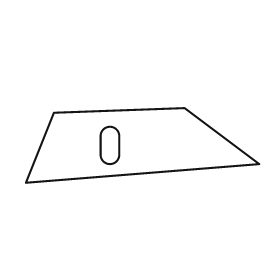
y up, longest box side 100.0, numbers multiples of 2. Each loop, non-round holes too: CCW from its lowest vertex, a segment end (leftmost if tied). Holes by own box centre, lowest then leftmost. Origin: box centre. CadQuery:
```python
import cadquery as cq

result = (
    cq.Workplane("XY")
    .moveTo(-50.0, -16.0)
    .lineTo(50.0, -8.0)
    .lineTo(18.0, 16.0)
    .lineTo(-38.0, 14.0)
    .close()
    .moveTo(-18.0, -4.0)
    .threePointArc((-14.0, -8.0), (-10.0, -4.0))
    .lineTo(-10.0, 4.0)
    .threePointArc((-14.0, 8.0), (-18.0, 4.0))
    .close()
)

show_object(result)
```